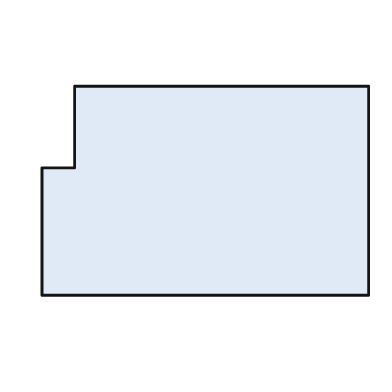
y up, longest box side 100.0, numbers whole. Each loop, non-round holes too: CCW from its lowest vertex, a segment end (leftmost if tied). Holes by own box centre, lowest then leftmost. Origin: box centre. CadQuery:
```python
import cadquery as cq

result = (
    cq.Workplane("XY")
    .moveTo(-50.0, -32.0)
    .lineTo(50.0, -32.0)
    .lineTo(50.0, 32.0)
    .lineTo(-40.0, 32.0)
    .lineTo(-40.0, 7.0)
    .lineTo(-50.0, 7.0)
    .close()
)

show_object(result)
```